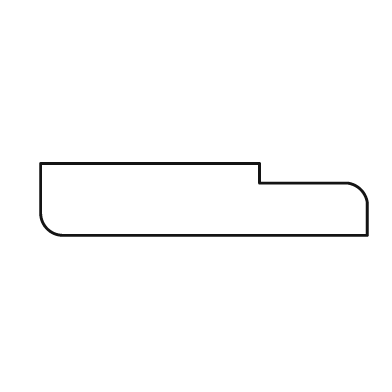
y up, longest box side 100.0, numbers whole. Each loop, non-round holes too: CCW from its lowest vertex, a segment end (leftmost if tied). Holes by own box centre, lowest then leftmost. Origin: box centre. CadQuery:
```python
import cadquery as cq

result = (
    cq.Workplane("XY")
    .moveTo(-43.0, -11.0)
    .lineTo(50.0, -11.0)
    .lineTo(50.0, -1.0)
    .threePointArc((48.0, 3.0), (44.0, 5.0))
    .lineTo(17.0, 5.0)
    .lineTo(17.0, 11.0)
    .lineTo(-50.0, 11.0)
    .lineTo(-50.0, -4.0)
    .threePointArc((-48.0, -9.0), (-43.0, -11.0))
    .close()
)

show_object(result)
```